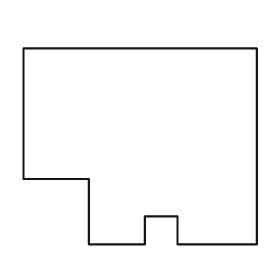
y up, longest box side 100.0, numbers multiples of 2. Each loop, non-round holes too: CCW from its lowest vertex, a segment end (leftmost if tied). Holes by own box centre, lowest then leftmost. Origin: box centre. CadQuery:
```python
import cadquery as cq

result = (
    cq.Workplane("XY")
    .moveTo(-22.0, -42.0)
    .lineTo(2.0, -42.0)
    .lineTo(2.0, -30.0)
    .lineTo(16.0, -30.0)
    .lineTo(16.0, -42.0)
    .lineTo(50.0, -42.0)
    .lineTo(50.0, 42.0)
    .lineTo(-50.0, 42.0)
    .lineTo(-50.0, -14.0)
    .lineTo(-22.0, -14.0)
    .close()
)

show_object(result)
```